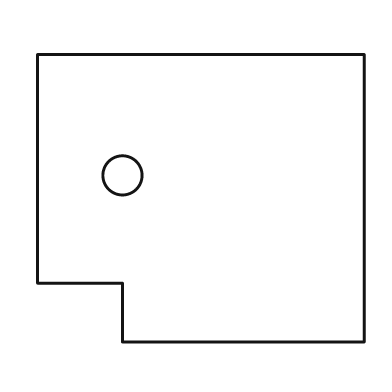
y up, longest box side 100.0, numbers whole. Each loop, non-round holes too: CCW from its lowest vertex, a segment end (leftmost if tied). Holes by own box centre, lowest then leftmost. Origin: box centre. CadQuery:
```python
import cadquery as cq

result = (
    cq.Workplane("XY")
    .moveTo(-24.0, -44.0)
    .lineTo(50.0, -44.0)
    .lineTo(50.0, 44.0)
    .lineTo(-50.0, 44.0)
    .lineTo(-50.0, -26.0)
    .lineTo(-24.0, -26.0)
    .close()
    .moveTo(-24.0, 7.0)
    .circle(6.0)
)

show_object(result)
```